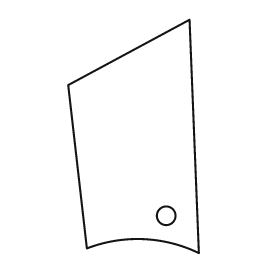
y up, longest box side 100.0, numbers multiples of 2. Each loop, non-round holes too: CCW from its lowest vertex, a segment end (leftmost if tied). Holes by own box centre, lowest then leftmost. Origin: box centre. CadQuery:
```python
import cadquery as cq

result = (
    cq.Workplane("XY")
    .moveTo(28.0, -50.0)
    .lineTo(24.0, 50.0)
    .lineTo(-28.0, 22.0)
    .lineTo(-20.0, -48.0)
    .threePointArc((4.0, -44.0), (28.0, -50.0))
    .close()
    .moveTo(14.0, -34.0)
    .circle(4.0)
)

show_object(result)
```